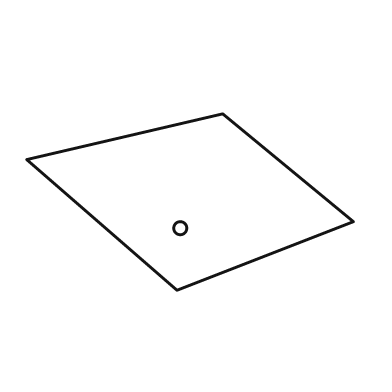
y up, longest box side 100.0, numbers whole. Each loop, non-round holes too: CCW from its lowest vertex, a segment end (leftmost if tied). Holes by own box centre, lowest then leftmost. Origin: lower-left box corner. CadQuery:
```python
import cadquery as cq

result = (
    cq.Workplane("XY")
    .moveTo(46.0, 0.0)
    .lineTo(100.0, 21.0)
    .lineTo(60.0, 54.0)
    .lineTo(0.0, 40.0)
    .close()
    .moveTo(47.0, 19.0)
    .circle(2.0)
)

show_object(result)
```